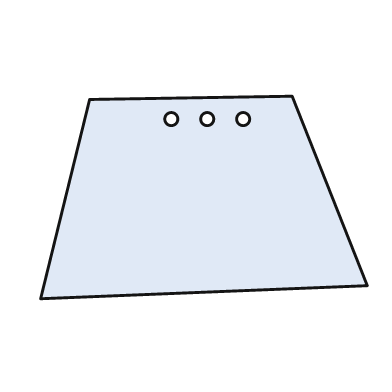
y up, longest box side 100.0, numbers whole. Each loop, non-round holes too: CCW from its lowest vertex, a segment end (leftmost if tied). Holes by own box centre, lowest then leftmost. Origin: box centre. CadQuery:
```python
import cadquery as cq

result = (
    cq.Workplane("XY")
    .moveTo(-50.0, -31.0)
    .lineTo(50.0, -27.0)
    .lineTo(27.0, 31.0)
    .lineTo(-35.0, 30.0)
    .close()
    .moveTo(-10.0, 24.0)
    .circle(2.0)
    .moveTo(1.0, 24.0)
    .circle(2.0)
    .moveTo(12.0, 24.0)
    .circle(2.0)
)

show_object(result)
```